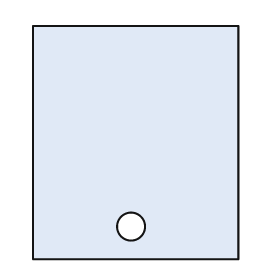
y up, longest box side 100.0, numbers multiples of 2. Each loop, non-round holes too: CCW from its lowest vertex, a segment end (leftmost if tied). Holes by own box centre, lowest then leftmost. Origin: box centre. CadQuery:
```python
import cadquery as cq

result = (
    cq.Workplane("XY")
    .moveTo(-44.0, -50.0)
    .lineTo(44.0, -50.0)
    .lineTo(44.0, 50.0)
    .lineTo(-44.0, 50.0)
    .close()
    .moveTo(-2.0, -36.0)
    .circle(6.0)
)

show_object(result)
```